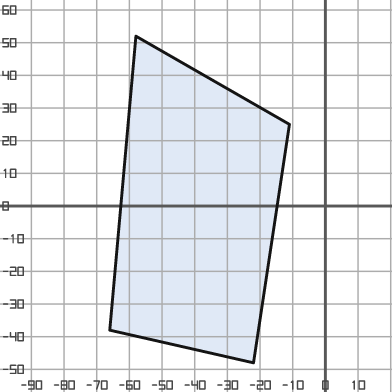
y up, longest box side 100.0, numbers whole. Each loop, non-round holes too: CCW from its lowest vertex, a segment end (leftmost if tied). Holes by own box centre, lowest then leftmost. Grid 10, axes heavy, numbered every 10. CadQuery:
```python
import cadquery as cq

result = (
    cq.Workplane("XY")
    .moveTo(-22.0, -48.0)
    .lineTo(-11.0, 25.0)
    .lineTo(-58.0, 52.0)
    .lineTo(-66.0, -38.0)
    .close()
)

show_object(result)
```